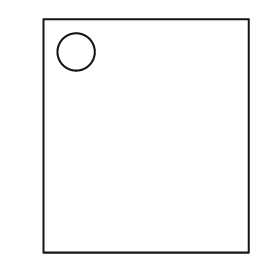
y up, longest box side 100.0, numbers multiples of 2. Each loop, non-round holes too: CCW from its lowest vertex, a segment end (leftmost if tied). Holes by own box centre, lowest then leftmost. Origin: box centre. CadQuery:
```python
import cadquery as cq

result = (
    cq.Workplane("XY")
    .moveTo(-44.0, -50.0)
    .lineTo(44.0, -50.0)
    .lineTo(44.0, 50.0)
    .lineTo(-44.0, 50.0)
    .close()
    .moveTo(-30.0, 36.0)
    .circle(8.0)
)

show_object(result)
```